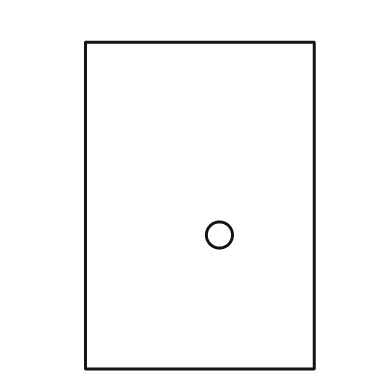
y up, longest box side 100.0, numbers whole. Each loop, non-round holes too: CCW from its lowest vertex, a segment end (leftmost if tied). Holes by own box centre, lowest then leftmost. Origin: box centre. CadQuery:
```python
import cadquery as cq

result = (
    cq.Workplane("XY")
    .moveTo(-35.0, -50.0)
    .lineTo(35.0, -50.0)
    .lineTo(35.0, 50.0)
    .lineTo(-35.0, 50.0)
    .close()
    .moveTo(6.0, -9.0)
    .circle(4.0)
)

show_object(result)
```